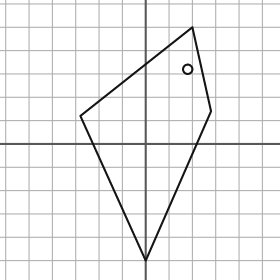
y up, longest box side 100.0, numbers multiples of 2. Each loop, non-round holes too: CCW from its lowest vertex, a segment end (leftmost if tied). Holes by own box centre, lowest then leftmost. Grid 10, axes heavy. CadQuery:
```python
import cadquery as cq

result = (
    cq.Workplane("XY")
    .moveTo(0.0, -50.0)
    .lineTo(28.0, 14.0)
    .lineTo(20.0, 50.0)
    .lineTo(-28.0, 12.0)
    .close()
    .moveTo(18.0, 32.0)
    .circle(2.0)
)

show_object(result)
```